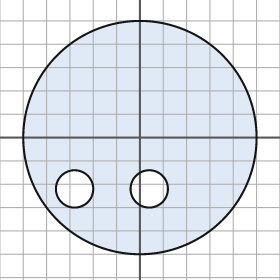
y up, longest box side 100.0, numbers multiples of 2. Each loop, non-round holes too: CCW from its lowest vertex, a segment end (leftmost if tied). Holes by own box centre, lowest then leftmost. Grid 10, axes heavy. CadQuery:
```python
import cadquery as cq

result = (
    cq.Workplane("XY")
    .moveTo(0.0, 0.0)
    .circle(50.0)
    .moveTo(-28.0, -22.0)
    .circle(8.0)
    .moveTo(4.0, -22.0)
    .circle(8.0)
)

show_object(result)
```